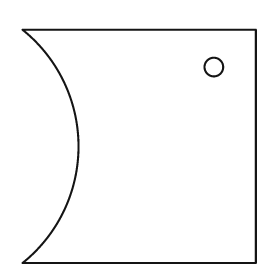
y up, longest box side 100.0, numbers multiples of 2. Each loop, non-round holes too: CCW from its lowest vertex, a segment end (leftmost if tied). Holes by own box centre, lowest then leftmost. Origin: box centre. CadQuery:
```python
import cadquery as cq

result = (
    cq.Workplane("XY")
    .moveTo(-50.0, -50.0)
    .lineTo(50.0, -50.0)
    .lineTo(50.0, 50.0)
    .lineTo(-50.0, 50.0)
    .threePointArc((-26.0, 0.0), (-50.0, -50.0))
    .close()
    .moveTo(32.0, 34.0)
    .circle(4.0)
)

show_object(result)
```